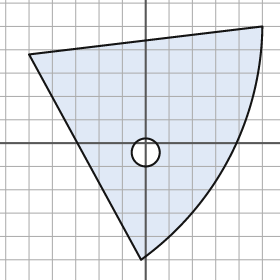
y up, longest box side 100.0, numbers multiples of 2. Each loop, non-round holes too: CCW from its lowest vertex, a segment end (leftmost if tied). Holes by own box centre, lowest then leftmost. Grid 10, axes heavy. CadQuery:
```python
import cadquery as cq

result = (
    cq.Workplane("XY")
    .moveTo(-2.0, -50.0)
    .threePointArc((36.0, -6.0), (50.0, 50.0))
    .lineTo(-50.0, 38.0)
    .close()
    .moveTo(0.0, -4.0)
    .circle(6.0)
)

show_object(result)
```